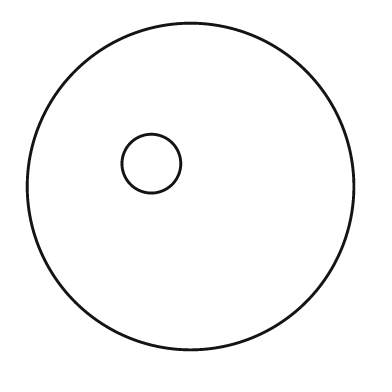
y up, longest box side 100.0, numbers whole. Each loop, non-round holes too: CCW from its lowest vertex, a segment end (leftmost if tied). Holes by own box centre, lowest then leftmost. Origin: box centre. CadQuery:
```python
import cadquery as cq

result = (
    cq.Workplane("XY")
    .moveTo(0.0, 0.0)
    .circle(50.0)
    .moveTo(-12.0, 7.0)
    .circle(9.0)
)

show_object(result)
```